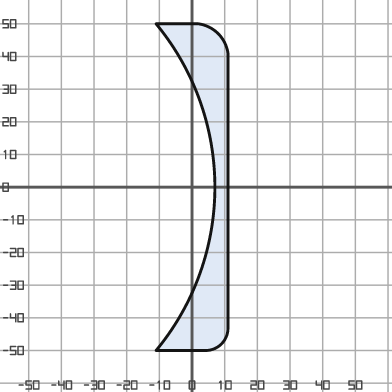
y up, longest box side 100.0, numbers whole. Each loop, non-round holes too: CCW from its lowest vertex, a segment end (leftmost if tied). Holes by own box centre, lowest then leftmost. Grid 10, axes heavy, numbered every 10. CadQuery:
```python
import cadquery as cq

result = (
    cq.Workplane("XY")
    .moveTo(-11.0, -50.0)
    .lineTo(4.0, -50.0)
    .threePointArc((9.0, -48.0), (11.0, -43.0))
    .lineTo(11.0, 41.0)
    .threePointArc((8.0, 47.0), (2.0, 50.0))
    .lineTo(-11.0, 50.0)
    .threePointArc((7.0, 0.0), (-11.0, -50.0))
    .close()
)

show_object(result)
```